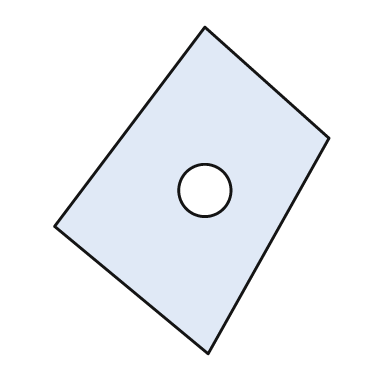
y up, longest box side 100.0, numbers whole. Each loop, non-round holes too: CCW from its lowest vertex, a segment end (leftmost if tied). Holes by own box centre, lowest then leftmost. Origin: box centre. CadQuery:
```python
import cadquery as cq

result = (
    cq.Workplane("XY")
    .moveTo(5.0, -50.0)
    .lineTo(42.0, 16.0)
    .lineTo(4.0, 50.0)
    .lineTo(-42.0, -11.0)
    .close()
    .moveTo(4.0, 0.0)
    .circle(8.0)
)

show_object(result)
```